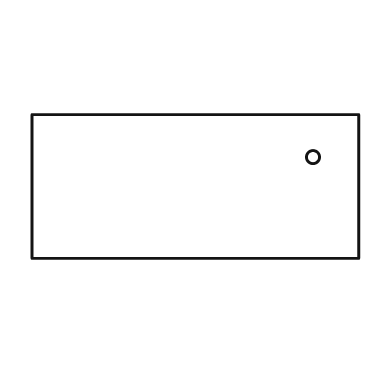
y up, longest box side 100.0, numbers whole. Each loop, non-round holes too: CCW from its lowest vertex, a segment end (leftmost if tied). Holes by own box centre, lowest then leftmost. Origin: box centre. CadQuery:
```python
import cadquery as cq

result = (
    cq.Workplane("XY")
    .moveTo(-50.0, -22.0)
    .lineTo(50.0, -22.0)
    .lineTo(50.0, 22.0)
    .lineTo(-50.0, 22.0)
    .close()
    .moveTo(36.0, 9.0)
    .circle(2.0)
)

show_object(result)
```